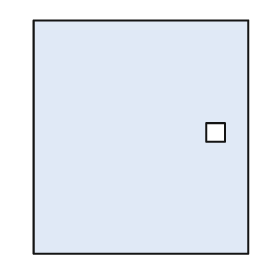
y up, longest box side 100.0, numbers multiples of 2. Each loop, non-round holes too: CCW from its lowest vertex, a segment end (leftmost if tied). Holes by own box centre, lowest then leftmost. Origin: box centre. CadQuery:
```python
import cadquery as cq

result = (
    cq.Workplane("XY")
    .moveTo(-46.0, -50.0)
    .lineTo(46.0, -50.0)
    .lineTo(46.0, 50.0)
    .lineTo(-46.0, 50.0)
    .close()
    .moveTo(28.0, -2.0)
    .lineTo(36.0, -2.0)
    .lineTo(36.0, 6.0)
    .lineTo(28.0, 6.0)
    .close()
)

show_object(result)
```